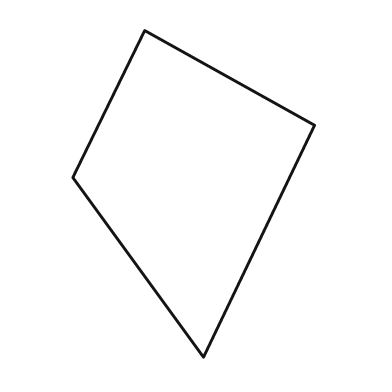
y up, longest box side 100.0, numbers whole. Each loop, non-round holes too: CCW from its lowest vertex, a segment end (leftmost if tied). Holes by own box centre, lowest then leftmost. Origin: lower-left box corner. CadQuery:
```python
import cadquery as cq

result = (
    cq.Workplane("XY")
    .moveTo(40.0, 0.0)
    .lineTo(74.0, 71.0)
    .lineTo(22.0, 100.0)
    .lineTo(0.0, 55.0)
    .close()
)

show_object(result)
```